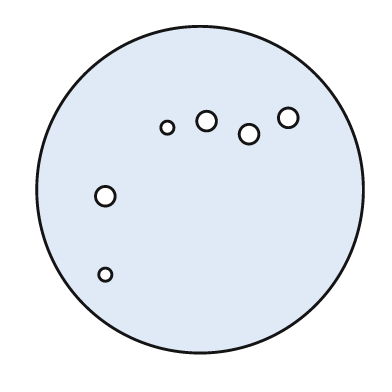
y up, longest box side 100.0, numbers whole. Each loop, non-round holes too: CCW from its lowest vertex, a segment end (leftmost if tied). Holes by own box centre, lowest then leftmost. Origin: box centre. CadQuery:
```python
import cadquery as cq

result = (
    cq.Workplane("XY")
    .moveTo(0.0, 0.0)
    .circle(50.0)
    .moveTo(-29.0, -26.0)
    .circle(2.0)
    .moveTo(-29.0, -2.0)
    .circle(3.0)
    .moveTo(15.0, 17.0)
    .circle(3.0)
    .moveTo(-10.0, 19.0)
    .circle(2.0)
    .moveTo(2.0, 21.0)
    .circle(3.0)
    .moveTo(27.0, 22.0)
    .circle(3.0)
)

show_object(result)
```